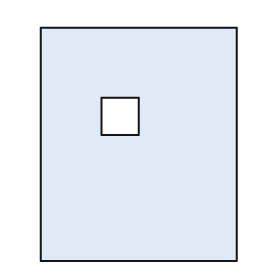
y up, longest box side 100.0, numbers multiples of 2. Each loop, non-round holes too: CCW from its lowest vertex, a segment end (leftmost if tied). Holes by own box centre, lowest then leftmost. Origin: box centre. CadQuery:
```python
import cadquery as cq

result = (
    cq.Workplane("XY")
    .moveTo(-42.0, -50.0)
    .lineTo(42.0, -50.0)
    .lineTo(42.0, 50.0)
    .lineTo(-42.0, 50.0)
    .close()
    .moveTo(-16.0, 4.0)
    .lineTo(0.0, 4.0)
    .lineTo(0.0, 20.0)
    .lineTo(-16.0, 20.0)
    .close()
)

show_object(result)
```